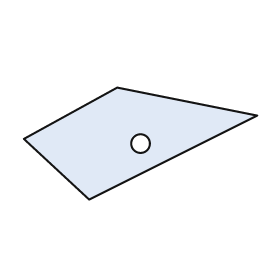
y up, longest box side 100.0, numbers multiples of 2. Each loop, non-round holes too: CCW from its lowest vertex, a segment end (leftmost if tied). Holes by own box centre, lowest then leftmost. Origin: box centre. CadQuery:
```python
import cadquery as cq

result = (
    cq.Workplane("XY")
    .moveTo(-22.0, -24.0)
    .lineTo(50.0, 12.0)
    .lineTo(-10.0, 24.0)
    .lineTo(-50.0, 2.0)
    .close()
    .moveTo(0.0, 0.0)
    .circle(4.0)
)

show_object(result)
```